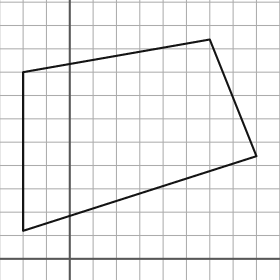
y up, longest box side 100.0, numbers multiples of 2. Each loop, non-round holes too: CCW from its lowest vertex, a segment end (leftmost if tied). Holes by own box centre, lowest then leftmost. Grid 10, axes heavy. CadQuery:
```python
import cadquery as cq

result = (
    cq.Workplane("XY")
    .moveTo(-20.0, 12.0)
    .lineTo(80.0, 44.0)
    .lineTo(60.0, 94.0)
    .lineTo(-20.0, 80.0)
    .close()
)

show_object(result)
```